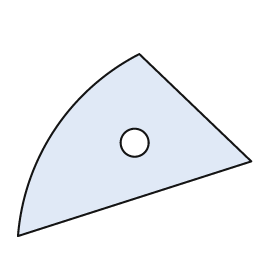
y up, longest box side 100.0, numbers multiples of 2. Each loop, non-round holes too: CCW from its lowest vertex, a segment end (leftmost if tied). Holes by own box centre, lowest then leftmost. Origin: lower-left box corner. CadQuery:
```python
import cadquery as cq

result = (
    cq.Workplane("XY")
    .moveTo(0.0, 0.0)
    .lineTo(100.0, 32.0)
    .lineTo(52.0, 78.0)
    .threePointArc((16.0, 46.0), (0.0, 0.0))
    .close()
    .moveTo(50.0, 40.0)
    .circle(6.0)
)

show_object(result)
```